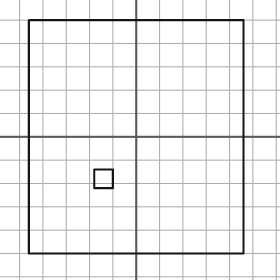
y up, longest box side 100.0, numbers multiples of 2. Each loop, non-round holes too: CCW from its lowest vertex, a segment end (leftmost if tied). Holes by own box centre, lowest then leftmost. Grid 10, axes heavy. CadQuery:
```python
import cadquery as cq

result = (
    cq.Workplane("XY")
    .moveTo(-46.0, -50.0)
    .lineTo(46.0, -50.0)
    .lineTo(46.0, 50.0)
    .lineTo(-46.0, 50.0)
    .close()
    .moveTo(-18.0, -22.0)
    .lineTo(-10.0, -22.0)
    .lineTo(-10.0, -14.0)
    .lineTo(-18.0, -14.0)
    .close()
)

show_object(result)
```